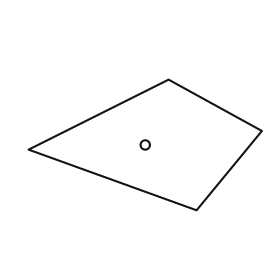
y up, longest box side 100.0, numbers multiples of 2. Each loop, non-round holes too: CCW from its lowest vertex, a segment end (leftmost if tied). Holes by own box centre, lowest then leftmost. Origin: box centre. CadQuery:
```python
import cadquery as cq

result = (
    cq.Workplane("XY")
    .moveTo(22.0, -28.0)
    .lineTo(50.0, 6.0)
    .lineTo(10.0, 28.0)
    .lineTo(-50.0, -2.0)
    .close()
    .moveTo(0.0, 0.0)
    .circle(2.0)
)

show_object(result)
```